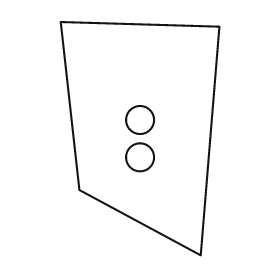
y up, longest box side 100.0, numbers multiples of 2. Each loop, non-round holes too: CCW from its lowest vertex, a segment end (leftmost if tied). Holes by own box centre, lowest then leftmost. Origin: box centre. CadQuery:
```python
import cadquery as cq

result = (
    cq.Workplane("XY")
    .moveTo(26.0, -50.0)
    .lineTo(34.0, 48.0)
    .lineTo(-34.0, 50.0)
    .lineTo(-26.0, -22.0)
    .close()
    .moveTo(0.0, -8.0)
    .circle(6.0)
    .moveTo(0.0, 8.0)
    .circle(6.0)
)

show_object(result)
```